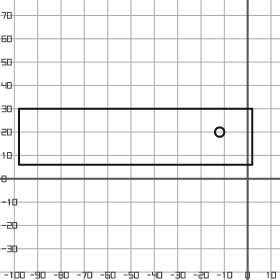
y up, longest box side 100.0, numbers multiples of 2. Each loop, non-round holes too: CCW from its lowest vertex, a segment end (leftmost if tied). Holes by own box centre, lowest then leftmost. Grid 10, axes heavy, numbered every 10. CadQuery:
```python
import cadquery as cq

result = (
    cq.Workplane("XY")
    .moveTo(-98.0, 6.0)
    .lineTo(2.0, 6.0)
    .lineTo(2.0, 30.0)
    .lineTo(-98.0, 30.0)
    .close()
    .moveTo(-12.0, 20.0)
    .circle(2.0)
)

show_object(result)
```